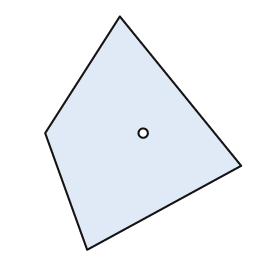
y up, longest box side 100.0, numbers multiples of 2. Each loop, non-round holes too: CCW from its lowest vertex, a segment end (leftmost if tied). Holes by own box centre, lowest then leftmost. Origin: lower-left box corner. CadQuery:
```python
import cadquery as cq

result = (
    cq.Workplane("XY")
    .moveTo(18.0, 0.0)
    .lineTo(84.0, 36.0)
    .lineTo(32.0, 100.0)
    .lineTo(0.0, 50.0)
    .close()
    .moveTo(42.0, 50.0)
    .circle(2.0)
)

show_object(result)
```